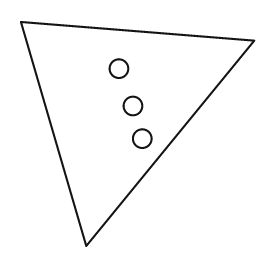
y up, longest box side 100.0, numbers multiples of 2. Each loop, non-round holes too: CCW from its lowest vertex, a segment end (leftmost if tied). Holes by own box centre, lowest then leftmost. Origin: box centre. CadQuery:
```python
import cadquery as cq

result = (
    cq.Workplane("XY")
    .moveTo(-22.0, -48.0)
    .lineTo(50.0, 40.0)
    .lineTo(-50.0, 48.0)
    .close()
    .moveTo(2.0, -2.0)
    .circle(4.0)
    .moveTo(-2.0, 12.0)
    .circle(4.0)
    .moveTo(-8.0, 28.0)
    .circle(4.0)
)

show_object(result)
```